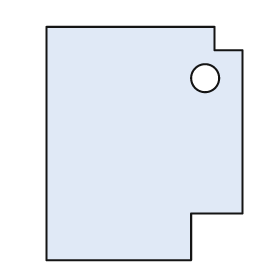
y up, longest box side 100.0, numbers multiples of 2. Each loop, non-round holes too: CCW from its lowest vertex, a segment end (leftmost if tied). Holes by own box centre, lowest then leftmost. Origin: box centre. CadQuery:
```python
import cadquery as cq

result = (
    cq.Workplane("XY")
    .moveTo(-42.0, -50.0)
    .lineTo(20.0, -50.0)
    .lineTo(20.0, -30.0)
    .lineTo(42.0, -30.0)
    .lineTo(42.0, 40.0)
    .lineTo(30.0, 40.0)
    .lineTo(30.0, 50.0)
    .lineTo(-42.0, 50.0)
    .close()
    .moveTo(26.0, 28.0)
    .circle(6.0)
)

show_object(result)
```